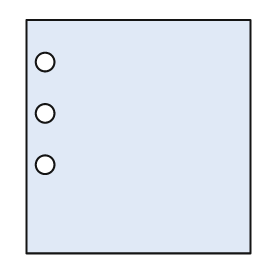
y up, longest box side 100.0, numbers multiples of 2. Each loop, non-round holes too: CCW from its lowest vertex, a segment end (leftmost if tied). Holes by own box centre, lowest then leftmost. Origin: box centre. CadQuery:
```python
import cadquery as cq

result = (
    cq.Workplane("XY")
    .moveTo(-48.0, -50.0)
    .lineTo(48.0, -50.0)
    .lineTo(48.0, 50.0)
    .lineTo(-48.0, 50.0)
    .close()
    .moveTo(-40.0, -12.0)
    .circle(4.0)
    .moveTo(-40.0, 10.0)
    .circle(4.0)
    .moveTo(-40.0, 32.0)
    .circle(4.0)
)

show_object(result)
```